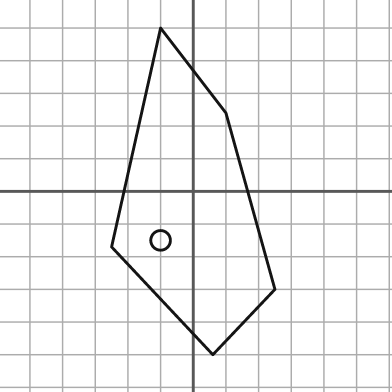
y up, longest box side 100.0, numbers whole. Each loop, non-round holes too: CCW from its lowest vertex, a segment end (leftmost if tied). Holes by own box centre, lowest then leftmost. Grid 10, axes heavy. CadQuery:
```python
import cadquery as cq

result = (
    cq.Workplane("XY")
    .moveTo(6.0, -50.0)
    .lineTo(25.0, -30.0)
    .lineTo(10.0, 24.0)
    .lineTo(-10.0, 50.0)
    .lineTo(-25.0, -17.0)
    .close()
    .moveTo(-10.0, -15.0)
    .circle(3.0)
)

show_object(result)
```